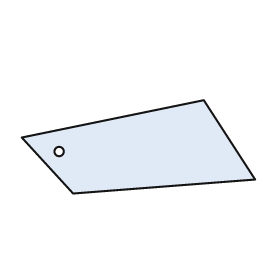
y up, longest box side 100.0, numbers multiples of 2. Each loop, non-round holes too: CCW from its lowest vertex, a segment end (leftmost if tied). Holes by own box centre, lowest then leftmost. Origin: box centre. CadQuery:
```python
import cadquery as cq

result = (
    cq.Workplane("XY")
    .moveTo(-28.0, -20.0)
    .lineTo(50.0, -14.0)
    .lineTo(28.0, 20.0)
    .lineTo(-50.0, 4.0)
    .close()
    .moveTo(-34.0, -2.0)
    .circle(2.0)
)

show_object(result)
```